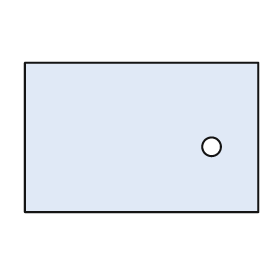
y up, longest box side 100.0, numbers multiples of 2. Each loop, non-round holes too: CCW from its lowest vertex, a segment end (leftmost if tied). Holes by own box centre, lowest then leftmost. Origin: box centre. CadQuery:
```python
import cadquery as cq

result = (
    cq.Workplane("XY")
    .moveTo(-50.0, -32.0)
    .lineTo(50.0, -32.0)
    .lineTo(50.0, 32.0)
    .lineTo(-50.0, 32.0)
    .close()
    .moveTo(30.0, -4.0)
    .circle(4.0)
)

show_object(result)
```